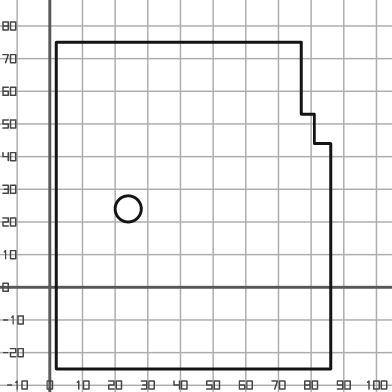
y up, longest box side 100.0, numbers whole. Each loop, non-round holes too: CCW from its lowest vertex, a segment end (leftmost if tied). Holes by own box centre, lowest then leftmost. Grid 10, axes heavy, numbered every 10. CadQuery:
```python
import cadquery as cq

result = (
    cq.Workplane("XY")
    .moveTo(2.0, -25.0)
    .lineTo(86.0, -25.0)
    .lineTo(86.0, 44.0)
    .lineTo(81.0, 44.0)
    .lineTo(81.0, 53.0)
    .lineTo(77.0, 53.0)
    .lineTo(77.0, 75.0)
    .lineTo(2.0, 75.0)
    .close()
    .moveTo(24.0, 24.0)
    .circle(4.0)
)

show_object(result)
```